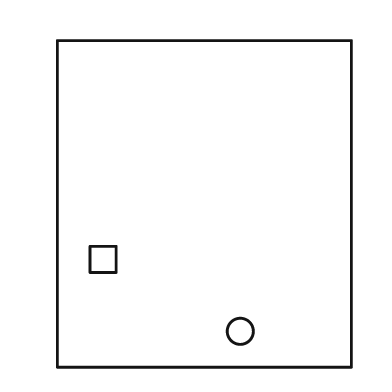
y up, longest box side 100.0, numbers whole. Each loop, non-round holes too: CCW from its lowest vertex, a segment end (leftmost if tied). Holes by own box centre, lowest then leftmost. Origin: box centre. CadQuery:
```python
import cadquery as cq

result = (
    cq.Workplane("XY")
    .moveTo(-45.0, -50.0)
    .lineTo(45.0, -50.0)
    .lineTo(45.0, 50.0)
    .lineTo(-45.0, 50.0)
    .close()
    .moveTo(11.0, -39.0)
    .circle(4.0)
    .moveTo(-35.0, -21.0)
    .lineTo(-27.0, -21.0)
    .lineTo(-27.0, -13.0)
    .lineTo(-35.0, -13.0)
    .close()
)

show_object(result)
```